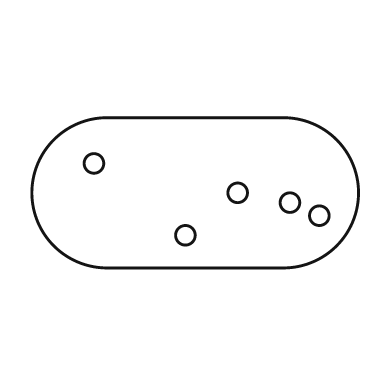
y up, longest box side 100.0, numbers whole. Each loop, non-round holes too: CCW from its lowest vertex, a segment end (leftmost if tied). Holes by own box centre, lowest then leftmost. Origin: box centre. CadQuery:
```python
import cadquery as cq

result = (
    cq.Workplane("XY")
    .moveTo(-27.0, -23.0)
    .lineTo(27.0, -23.0)
    .threePointArc((50.0, 0.0), (27.0, 23.0))
    .lineTo(-27.0, 23.0)
    .threePointArc((-50.0, 0.0), (-27.0, -23.0))
    .close()
    .moveTo(-3.0, -13.0)
    .circle(3.0)
    .moveTo(38.0, -7.0)
    .circle(3.0)
    .moveTo(29.0, -3.0)
    .circle(3.0)
    .moveTo(13.0, 0.0)
    .circle(3.0)
    .moveTo(-31.0, 9.0)
    .circle(3.0)
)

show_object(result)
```